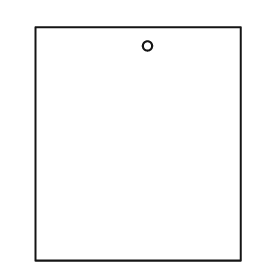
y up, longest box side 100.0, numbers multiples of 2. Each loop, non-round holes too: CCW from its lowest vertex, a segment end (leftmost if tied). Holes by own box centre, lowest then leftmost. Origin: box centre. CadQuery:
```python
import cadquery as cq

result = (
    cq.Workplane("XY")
    .moveTo(-44.0, -50.0)
    .lineTo(44.0, -50.0)
    .lineTo(44.0, 50.0)
    .lineTo(-44.0, 50.0)
    .close()
    .moveTo(4.0, 42.0)
    .circle(2.0)
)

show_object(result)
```